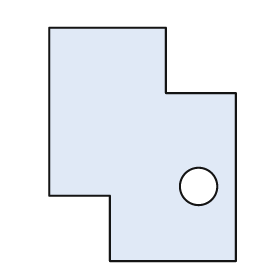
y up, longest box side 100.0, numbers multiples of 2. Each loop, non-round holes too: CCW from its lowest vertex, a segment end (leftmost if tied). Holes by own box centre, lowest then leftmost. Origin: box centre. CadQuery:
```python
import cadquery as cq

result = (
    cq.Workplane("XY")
    .moveTo(-14.0, -50.0)
    .lineTo(40.0, -50.0)
    .lineTo(40.0, 22.0)
    .lineTo(10.0, 22.0)
    .lineTo(10.0, 50.0)
    .lineTo(-40.0, 50.0)
    .lineTo(-40.0, -22.0)
    .lineTo(-14.0, -22.0)
    .close()
    .moveTo(24.0, -18.0)
    .circle(8.0)
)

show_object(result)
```